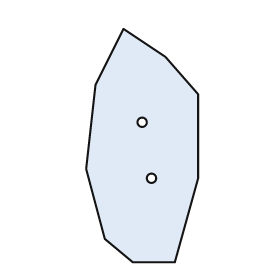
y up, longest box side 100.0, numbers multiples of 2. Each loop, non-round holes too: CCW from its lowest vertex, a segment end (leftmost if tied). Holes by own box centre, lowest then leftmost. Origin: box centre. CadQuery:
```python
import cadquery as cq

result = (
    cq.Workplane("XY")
    .moveTo(-4.0, -50.0)
    .lineTo(14.0, -50.0)
    .lineTo(24.0, -14.0)
    .lineTo(24.0, 22.0)
    .lineTo(10.0, 38.0)
    .lineTo(-8.0, 50.0)
    .lineTo(-20.0, 26.0)
    .lineTo(-24.0, -10.0)
    .lineTo(-16.0, -40.0)
    .close()
    .moveTo(4.0, -14.0)
    .circle(2.0)
    .moveTo(0.0, 10.0)
    .circle(2.0)
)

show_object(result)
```